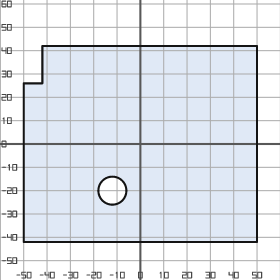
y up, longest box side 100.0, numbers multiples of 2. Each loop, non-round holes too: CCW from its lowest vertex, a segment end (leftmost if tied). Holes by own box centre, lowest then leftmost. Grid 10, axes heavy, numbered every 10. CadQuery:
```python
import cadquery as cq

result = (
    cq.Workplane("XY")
    .moveTo(-50.0, -42.0)
    .lineTo(50.0, -42.0)
    .lineTo(50.0, 42.0)
    .lineTo(-42.0, 42.0)
    .lineTo(-42.0, 26.0)
    .lineTo(-50.0, 26.0)
    .close()
    .moveTo(-12.0, -20.0)
    .circle(6.0)
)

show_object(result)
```